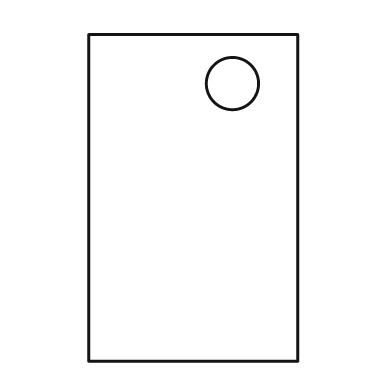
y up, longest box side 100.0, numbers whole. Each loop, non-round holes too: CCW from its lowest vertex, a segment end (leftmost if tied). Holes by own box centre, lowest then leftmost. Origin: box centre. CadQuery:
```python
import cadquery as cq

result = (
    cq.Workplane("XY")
    .moveTo(-32.0, -50.0)
    .lineTo(32.0, -50.0)
    .lineTo(32.0, 50.0)
    .lineTo(-32.0, 50.0)
    .close()
    .moveTo(12.0, 35.0)
    .circle(8.0)
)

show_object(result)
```